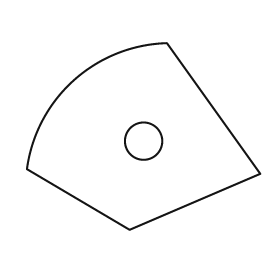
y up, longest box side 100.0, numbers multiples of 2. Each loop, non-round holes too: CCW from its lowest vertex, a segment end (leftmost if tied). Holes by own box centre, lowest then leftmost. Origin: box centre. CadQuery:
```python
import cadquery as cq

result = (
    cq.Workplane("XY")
    .moveTo(-6.0, -40.0)
    .lineTo(50.0, -16.0)
    .lineTo(10.0, 40.0)
    .threePointArc((-30.0, 24.0), (-50.0, -14.0))
    .close()
    .moveTo(0.0, -2.0)
    .circle(8.0)
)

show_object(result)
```